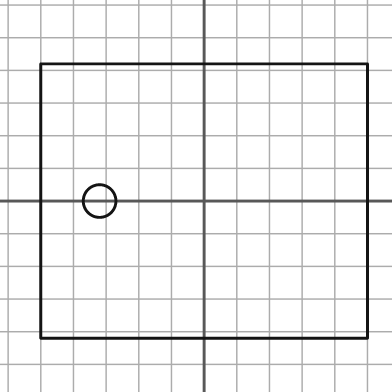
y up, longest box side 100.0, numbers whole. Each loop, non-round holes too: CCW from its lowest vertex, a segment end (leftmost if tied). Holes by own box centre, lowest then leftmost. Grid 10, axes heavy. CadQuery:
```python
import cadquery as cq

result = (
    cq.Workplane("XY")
    .moveTo(-50.0, -42.0)
    .lineTo(50.0, -42.0)
    .lineTo(50.0, 42.0)
    .lineTo(-50.0, 42.0)
    .close()
    .moveTo(-32.0, 0.0)
    .circle(5.0)
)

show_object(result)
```